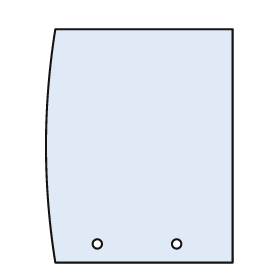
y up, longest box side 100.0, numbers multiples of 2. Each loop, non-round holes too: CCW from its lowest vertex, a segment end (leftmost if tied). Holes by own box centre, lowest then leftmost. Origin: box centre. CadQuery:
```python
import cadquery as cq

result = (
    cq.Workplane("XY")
    .moveTo(-36.0, -50.0)
    .lineTo(40.0, -50.0)
    .lineTo(40.0, 50.0)
    .lineTo(-36.0, 50.0)
    .threePointArc((-40.0, 0.0), (-36.0, -50.0))
    .close()
    .moveTo(-18.0, -42.0)
    .circle(2.0)
    .moveTo(16.0, -42.0)
    .circle(2.0)
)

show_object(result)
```